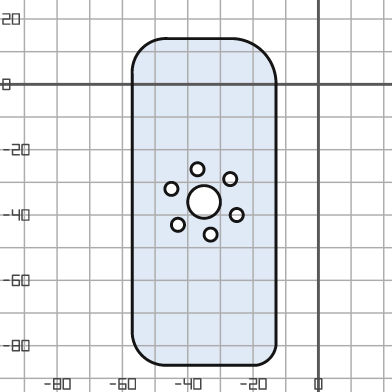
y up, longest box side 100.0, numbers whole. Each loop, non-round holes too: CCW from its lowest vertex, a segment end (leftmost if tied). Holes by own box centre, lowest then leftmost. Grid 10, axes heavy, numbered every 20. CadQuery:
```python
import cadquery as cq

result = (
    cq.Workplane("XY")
    .moveTo(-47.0, -86.0)
    .lineTo(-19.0, -86.0)
    .threePointArc((-15.0, -84.0), (-13.0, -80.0))
    .lineTo(-13.0, 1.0)
    .threePointArc((-17.0, 10.0), (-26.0, 14.0))
    .lineTo(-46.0, 14.0)
    .threePointArc((-54.0, 11.0), (-57.0, 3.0))
    .lineTo(-57.0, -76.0)
    .threePointArc((-54.0, -83.0), (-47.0, -86.0))
    .close()
    .moveTo(-33.0, -46.0)
    .circle(2.0)
    .moveTo(-43.0, -43.0)
    .circle(2.0)
    .moveTo(-25.0, -40.0)
    .circle(2.0)
    .moveTo(-35.0, -36.0)
    .circle(5.0)
    .moveTo(-45.0, -32.0)
    .circle(2.0)
    .moveTo(-27.0, -29.0)
    .circle(2.0)
    .moveTo(-37.0, -26.0)
    .circle(2.0)
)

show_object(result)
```